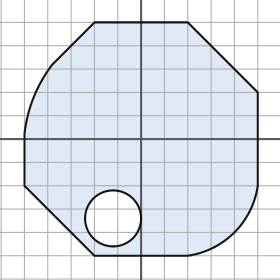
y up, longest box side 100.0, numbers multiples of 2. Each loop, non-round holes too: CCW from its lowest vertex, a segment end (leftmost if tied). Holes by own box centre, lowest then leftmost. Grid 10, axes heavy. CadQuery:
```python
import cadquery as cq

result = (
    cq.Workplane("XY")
    .moveTo(-20.0, -50.0)
    .lineTo(20.0, -50.0)
    .threePointArc((40.0, -40.0), (50.0, -20.0))
    .lineTo(50.0, 20.0)
    .lineTo(20.0, 50.0)
    .lineTo(-20.0, 50.0)
    .lineTo(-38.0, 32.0)
    .threePointArc((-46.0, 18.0), (-50.0, 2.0))
    .lineTo(-50.0, -20.0)
    .close()
    .moveTo(-12.0, -34.0)
    .circle(12.0)
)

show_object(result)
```